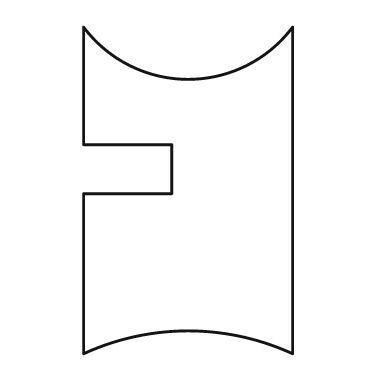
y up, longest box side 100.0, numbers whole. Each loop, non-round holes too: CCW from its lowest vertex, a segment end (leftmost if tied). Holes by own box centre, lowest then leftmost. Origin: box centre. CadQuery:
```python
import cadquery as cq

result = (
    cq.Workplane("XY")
    .moveTo(-32.0, -50.0)
    .threePointArc((0.0, -43.0), (32.0, -50.0))
    .lineTo(32.0, 50.0)
    .threePointArc((0.0, 34.0), (-32.0, 50.0))
    .lineTo(-32.0, 14.0)
    .lineTo(-5.0, 14.0)
    .lineTo(-5.0, -1.0)
    .lineTo(-32.0, -1.0)
    .close()
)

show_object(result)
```